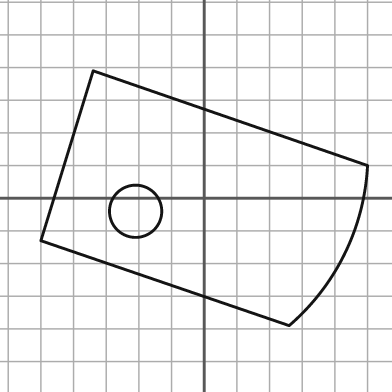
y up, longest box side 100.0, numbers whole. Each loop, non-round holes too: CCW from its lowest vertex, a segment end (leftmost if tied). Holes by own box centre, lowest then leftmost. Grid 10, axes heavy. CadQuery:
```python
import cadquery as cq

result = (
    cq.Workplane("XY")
    .moveTo(26.0, -39.0)
    .threePointArc((43.0, -17.0), (50.0, 10.0))
    .lineTo(-34.0, 39.0)
    .lineTo(-50.0, -13.0)
    .close()
    .moveTo(-21.0, -4.0)
    .circle(8.0)
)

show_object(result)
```